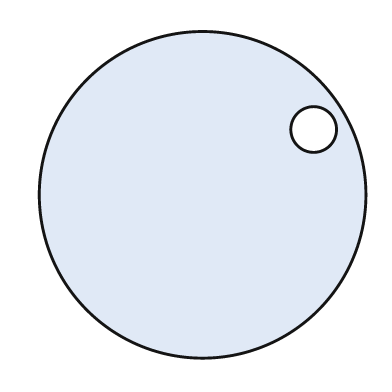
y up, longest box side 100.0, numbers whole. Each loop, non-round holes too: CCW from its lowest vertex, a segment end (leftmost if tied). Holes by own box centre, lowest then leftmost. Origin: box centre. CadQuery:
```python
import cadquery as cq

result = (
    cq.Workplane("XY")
    .moveTo(0.0, 0.0)
    .circle(50.0)
    .moveTo(34.0, 20.0)
    .circle(7.0)
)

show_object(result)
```